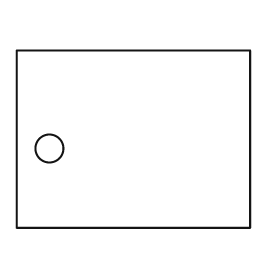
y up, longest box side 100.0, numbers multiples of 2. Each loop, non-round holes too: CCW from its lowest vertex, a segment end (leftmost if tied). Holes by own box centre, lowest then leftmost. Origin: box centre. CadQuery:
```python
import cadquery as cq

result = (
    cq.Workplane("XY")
    .moveTo(-50.0, -38.0)
    .lineTo(50.0, -38.0)
    .lineTo(50.0, 38.0)
    .lineTo(-50.0, 38.0)
    .close()
    .moveTo(-36.0, -4.0)
    .circle(6.0)
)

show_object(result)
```